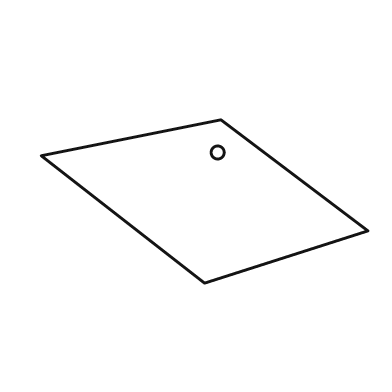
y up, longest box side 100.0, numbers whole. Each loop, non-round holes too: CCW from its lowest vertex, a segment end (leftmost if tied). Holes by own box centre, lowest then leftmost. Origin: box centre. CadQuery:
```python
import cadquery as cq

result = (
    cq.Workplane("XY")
    .moveTo(0.0, -25.0)
    .lineTo(50.0, -9.0)
    .lineTo(5.0, 25.0)
    .lineTo(-50.0, 14.0)
    .close()
    .moveTo(4.0, 15.0)
    .circle(2.0)
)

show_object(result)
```